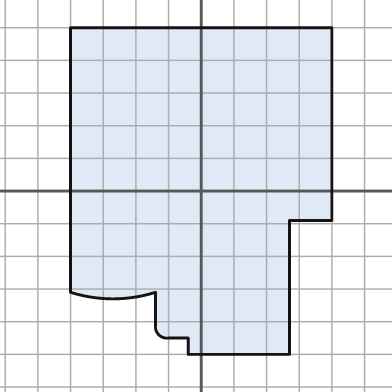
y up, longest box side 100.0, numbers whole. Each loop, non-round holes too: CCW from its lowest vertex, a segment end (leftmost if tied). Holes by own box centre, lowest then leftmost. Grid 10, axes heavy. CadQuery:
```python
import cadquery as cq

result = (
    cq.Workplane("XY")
    .moveTo(-4.0, -50.0)
    .lineTo(27.0, -50.0)
    .lineTo(27.0, -9.0)
    .lineTo(40.0, -9.0)
    .lineTo(40.0, 50.0)
    .lineTo(-40.0, 50.0)
    .lineTo(-40.0, -31.0)
    .threePointArc((-27.0, -33.0), (-14.0, -31.0))
    .lineTo(-14.0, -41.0)
    .threePointArc((-13.0, -44.0), (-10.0, -45.0))
    .lineTo(-4.0, -45.0)
    .close()
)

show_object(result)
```